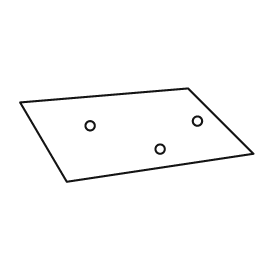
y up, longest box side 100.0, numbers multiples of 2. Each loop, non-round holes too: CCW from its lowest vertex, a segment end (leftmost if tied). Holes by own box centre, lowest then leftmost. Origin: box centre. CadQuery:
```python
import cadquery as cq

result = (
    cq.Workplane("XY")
    .moveTo(-30.0, -20.0)
    .lineTo(50.0, -8.0)
    .lineTo(22.0, 20.0)
    .lineTo(-50.0, 14.0)
    .close()
    .moveTo(10.0, -6.0)
    .circle(2.0)
    .moveTo(-20.0, 4.0)
    .circle(2.0)
    .moveTo(26.0, 6.0)
    .circle(2.0)
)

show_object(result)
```